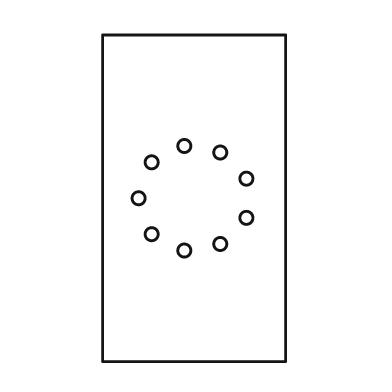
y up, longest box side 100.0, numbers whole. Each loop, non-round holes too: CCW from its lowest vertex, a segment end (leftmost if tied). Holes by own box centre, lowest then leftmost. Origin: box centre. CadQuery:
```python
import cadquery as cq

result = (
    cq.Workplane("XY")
    .moveTo(-28.0, -50.0)
    .lineTo(28.0, -50.0)
    .lineTo(28.0, 50.0)
    .lineTo(-28.0, 50.0)
    .close()
    .moveTo(-3.0, -16.0)
    .circle(2.0)
    .moveTo(8.0, -14.0)
    .circle(2.0)
    .moveTo(-13.0, -11.0)
    .circle(2.0)
    .moveTo(16.0, -6.0)
    .circle(2.0)
    .moveTo(-17.0, 0.0)
    .circle(2.0)
    .moveTo(16.0, 6.0)
    .circle(2.0)
    .moveTo(-13.0, 11.0)
    .circle(2.0)
    .moveTo(8.0, 14.0)
    .circle(2.0)
    .moveTo(-3.0, 16.0)
    .circle(2.0)
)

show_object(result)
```